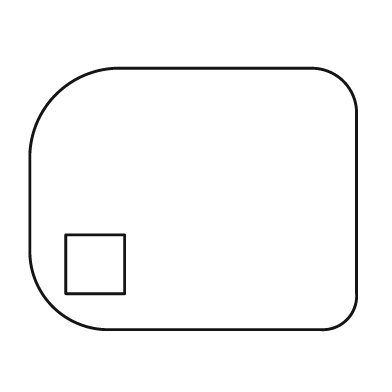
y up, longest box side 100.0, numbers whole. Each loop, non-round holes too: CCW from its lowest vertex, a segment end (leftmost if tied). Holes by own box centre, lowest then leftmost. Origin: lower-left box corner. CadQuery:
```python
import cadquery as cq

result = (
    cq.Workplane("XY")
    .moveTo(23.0, 0.0)
    .lineTo(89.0, 0.0)
    .threePointArc((97.0, 3.0), (100.0, 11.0))
    .lineTo(100.0, 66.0)
    .threePointArc((96.0, 76.0), (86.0, 80.0))
    .lineTo(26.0, 80.0)
    .threePointArc((8.0, 72.0), (0.0, 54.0))
    .lineTo(0.0, 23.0)
    .threePointArc((7.0, 7.0), (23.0, 0.0))
    .close()
    .moveTo(11.0, 11.0)
    .lineTo(29.0, 11.0)
    .lineTo(29.0, 29.0)
    .lineTo(11.0, 29.0)
    .close()
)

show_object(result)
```